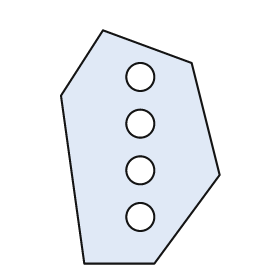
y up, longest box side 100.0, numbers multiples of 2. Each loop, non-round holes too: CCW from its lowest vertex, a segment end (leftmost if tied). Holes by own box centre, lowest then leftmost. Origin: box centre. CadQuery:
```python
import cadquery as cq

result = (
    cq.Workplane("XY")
    .moveTo(-24.0, -50.0)
    .lineTo(6.0, -50.0)
    .lineTo(34.0, -12.0)
    .lineTo(22.0, 36.0)
    .lineTo(-16.0, 50.0)
    .lineTo(-34.0, 22.0)
    .close()
    .moveTo(0.0, -30.0)
    .circle(6.0)
    .moveTo(0.0, -10.0)
    .circle(6.0)
    .moveTo(0.0, 10.0)
    .circle(6.0)
    .moveTo(0.0, 30.0)
    .circle(6.0)
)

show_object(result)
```